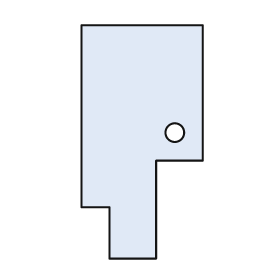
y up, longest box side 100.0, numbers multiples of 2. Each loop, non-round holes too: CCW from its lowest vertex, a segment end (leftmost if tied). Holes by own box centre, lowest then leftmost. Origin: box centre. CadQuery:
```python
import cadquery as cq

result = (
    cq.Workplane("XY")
    .moveTo(-14.0, -50.0)
    .lineTo(6.0, -50.0)
    .lineTo(6.0, -8.0)
    .lineTo(26.0, -8.0)
    .lineTo(26.0, 50.0)
    .lineTo(-26.0, 50.0)
    .lineTo(-26.0, -28.0)
    .lineTo(-14.0, -28.0)
    .close()
    .moveTo(14.0, 4.0)
    .circle(4.0)
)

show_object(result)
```